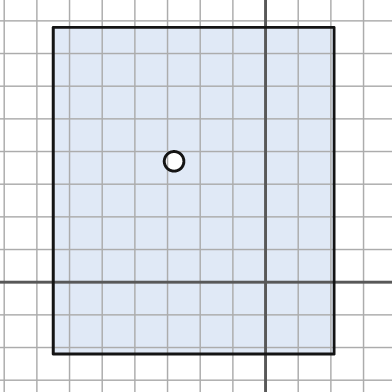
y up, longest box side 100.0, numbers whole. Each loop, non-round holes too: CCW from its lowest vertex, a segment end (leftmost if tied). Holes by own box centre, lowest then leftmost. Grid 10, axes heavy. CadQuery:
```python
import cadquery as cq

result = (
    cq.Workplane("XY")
    .moveTo(-65.0, -22.0)
    .lineTo(21.0, -22.0)
    .lineTo(21.0, 78.0)
    .lineTo(-65.0, 78.0)
    .close()
    .moveTo(-28.0, 37.0)
    .circle(3.0)
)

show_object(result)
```